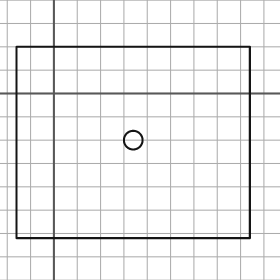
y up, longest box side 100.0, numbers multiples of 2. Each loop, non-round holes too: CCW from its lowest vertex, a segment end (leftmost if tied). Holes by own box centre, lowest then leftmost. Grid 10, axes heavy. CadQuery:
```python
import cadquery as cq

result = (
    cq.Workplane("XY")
    .moveTo(-16.0, -62.0)
    .lineTo(84.0, -62.0)
    .lineTo(84.0, 20.0)
    .lineTo(-16.0, 20.0)
    .close()
    .moveTo(34.0, -20.0)
    .circle(4.0)
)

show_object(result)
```